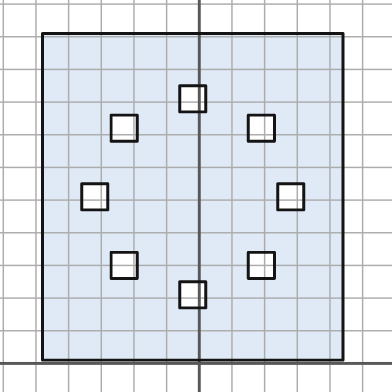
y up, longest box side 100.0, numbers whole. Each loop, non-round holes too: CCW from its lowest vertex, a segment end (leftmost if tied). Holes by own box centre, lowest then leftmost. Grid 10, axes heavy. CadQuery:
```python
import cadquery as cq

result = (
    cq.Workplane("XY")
    .moveTo(-48.0, 1.0)
    .lineTo(44.0, 1.0)
    .lineTo(44.0, 101.0)
    .lineTo(-48.0, 101.0)
    .close()
    .moveTo(-6.0, 17.0)
    .lineTo(2.0, 17.0)
    .lineTo(2.0, 25.0)
    .lineTo(-6.0, 25.0)
    .close()
    .moveTo(-27.0, 26.0)
    .lineTo(-19.0, 26.0)
    .lineTo(-19.0, 34.0)
    .lineTo(-27.0, 34.0)
    .close()
    .moveTo(15.0, 26.0)
    .lineTo(23.0, 26.0)
    .lineTo(23.0, 34.0)
    .lineTo(15.0, 34.0)
    .close()
    .moveTo(-36.0, 47.0)
    .lineTo(-28.0, 47.0)
    .lineTo(-28.0, 55.0)
    .lineTo(-36.0, 55.0)
    .close()
    .moveTo(24.0, 47.0)
    .lineTo(32.0, 47.0)
    .lineTo(32.0, 55.0)
    .lineTo(24.0, 55.0)
    .close()
    .moveTo(-27.0, 68.0)
    .lineTo(-19.0, 68.0)
    .lineTo(-19.0, 76.0)
    .lineTo(-27.0, 76.0)
    .close()
    .moveTo(15.0, 68.0)
    .lineTo(23.0, 68.0)
    .lineTo(23.0, 76.0)
    .lineTo(15.0, 76.0)
    .close()
    .moveTo(-6.0, 77.0)
    .lineTo(2.0, 77.0)
    .lineTo(2.0, 85.0)
    .lineTo(-6.0, 85.0)
    .close()
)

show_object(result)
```